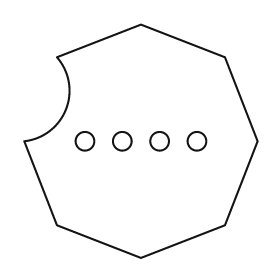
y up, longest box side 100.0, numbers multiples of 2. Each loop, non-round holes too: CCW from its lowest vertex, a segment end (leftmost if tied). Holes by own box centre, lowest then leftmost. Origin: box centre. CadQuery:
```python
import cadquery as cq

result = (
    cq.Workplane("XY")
    .moveTo(0.0, -50.0)
    .lineTo(36.0, -36.0)
    .lineTo(50.0, 0.0)
    .lineTo(36.0, 36.0)
    .lineTo(0.0, 50.0)
    .lineTo(-36.0, 36.0)
    .threePointArc((-32.0, 14.0), (-50.0, 0.0))
    .lineTo(-36.0, -36.0)
    .close()
    .moveTo(-24.0, 0.0)
    .circle(4.0)
    .moveTo(-8.0, 0.0)
    .circle(4.0)
    .moveTo(8.0, 0.0)
    .circle(4.0)
    .moveTo(24.0, 0.0)
    .circle(4.0)
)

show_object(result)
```